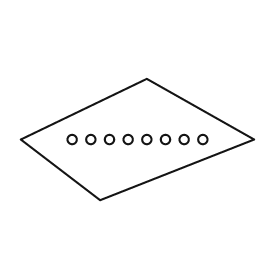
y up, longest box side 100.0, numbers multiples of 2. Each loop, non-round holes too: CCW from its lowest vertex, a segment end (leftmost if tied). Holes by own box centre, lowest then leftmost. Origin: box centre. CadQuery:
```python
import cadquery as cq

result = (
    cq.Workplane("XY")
    .moveTo(-16.0, -26.0)
    .lineTo(50.0, 0.0)
    .lineTo(4.0, 26.0)
    .lineTo(-50.0, 0.0)
    .close()
    .moveTo(-28.0, 0.0)
    .circle(2.0)
    .moveTo(-20.0, 0.0)
    .circle(2.0)
    .moveTo(-12.0, 0.0)
    .circle(2.0)
    .moveTo(-4.0, 0.0)
    .circle(2.0)
    .moveTo(4.0, 0.0)
    .circle(2.0)
    .moveTo(12.0, 0.0)
    .circle(2.0)
    .moveTo(20.0, 0.0)
    .circle(2.0)
    .moveTo(28.0, 0.0)
    .circle(2.0)
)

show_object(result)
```